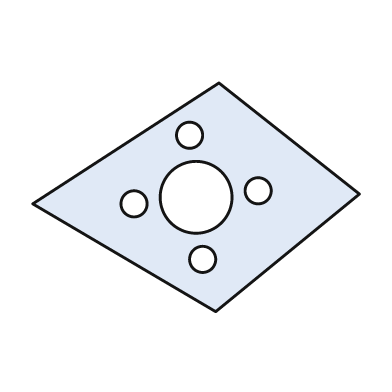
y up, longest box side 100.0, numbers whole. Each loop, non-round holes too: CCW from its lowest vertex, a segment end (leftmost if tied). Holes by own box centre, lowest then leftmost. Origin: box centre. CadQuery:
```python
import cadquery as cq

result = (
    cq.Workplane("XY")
    .moveTo(6.0, -35.0)
    .lineTo(50.0, 1.0)
    .lineTo(7.0, 35.0)
    .lineTo(-50.0, -2.0)
    .close()
    .moveTo(2.0, -19.0)
    .circle(4.0)
    .moveTo(-19.0, -2.0)
    .circle(4.0)
    .moveTo(0.0, 0.0)
    .circle(11.0)
    .moveTo(19.0, 2.0)
    .circle(4.0)
    .moveTo(-2.0, 19.0)
    .circle(4.0)
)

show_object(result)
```